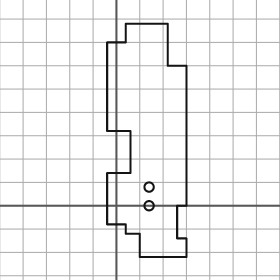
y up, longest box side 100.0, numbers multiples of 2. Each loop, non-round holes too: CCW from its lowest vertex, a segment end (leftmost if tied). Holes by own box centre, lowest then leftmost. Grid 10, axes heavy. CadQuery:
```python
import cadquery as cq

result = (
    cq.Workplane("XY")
    .moveTo(10.0, -22.0)
    .lineTo(30.0, -22.0)
    .lineTo(30.0, -14.0)
    .lineTo(26.0, -14.0)
    .lineTo(26.0, 0.0)
    .lineTo(30.0, 0.0)
    .lineTo(30.0, 60.0)
    .lineTo(22.0, 60.0)
    .lineTo(22.0, 78.0)
    .lineTo(4.0, 78.0)
    .lineTo(4.0, 70.0)
    .lineTo(-4.0, 70.0)
    .lineTo(-4.0, 32.0)
    .lineTo(6.0, 32.0)
    .lineTo(6.0, 14.0)
    .lineTo(-4.0, 14.0)
    .lineTo(-4.0, -8.0)
    .lineTo(4.0, -8.0)
    .lineTo(4.0, -12.0)
    .lineTo(10.0, -12.0)
    .close()
    .moveTo(14.0, 0.0)
    .circle(2.0)
    .moveTo(14.0, 8.0)
    .circle(2.0)
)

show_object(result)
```